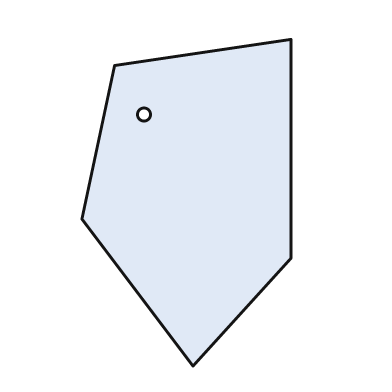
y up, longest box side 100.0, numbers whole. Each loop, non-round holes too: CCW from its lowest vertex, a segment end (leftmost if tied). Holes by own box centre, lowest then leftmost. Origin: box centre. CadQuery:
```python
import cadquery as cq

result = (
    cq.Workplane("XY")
    .moveTo(2.0, -50.0)
    .lineTo(32.0, -17.0)
    .lineTo(32.0, 50.0)
    .lineTo(-22.0, 42.0)
    .lineTo(-32.0, -5.0)
    .close()
    .moveTo(-13.0, 27.0)
    .circle(2.0)
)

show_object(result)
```